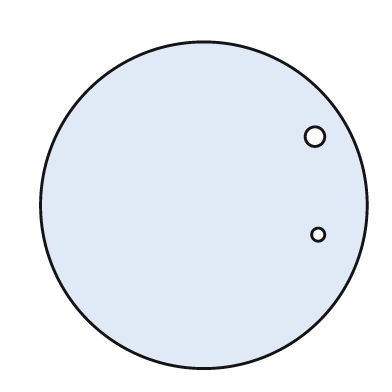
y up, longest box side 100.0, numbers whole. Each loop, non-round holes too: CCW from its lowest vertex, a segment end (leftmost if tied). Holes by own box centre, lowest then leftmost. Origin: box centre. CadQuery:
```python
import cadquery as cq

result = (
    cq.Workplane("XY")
    .moveTo(0.0, 0.0)
    .circle(50.0)
    .moveTo(35.0, -9.0)
    .circle(2.0)
    .moveTo(34.0, 21.0)
    .circle(3.0)
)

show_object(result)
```